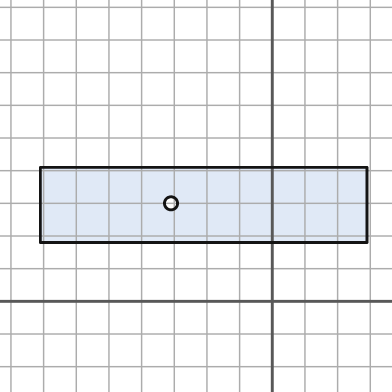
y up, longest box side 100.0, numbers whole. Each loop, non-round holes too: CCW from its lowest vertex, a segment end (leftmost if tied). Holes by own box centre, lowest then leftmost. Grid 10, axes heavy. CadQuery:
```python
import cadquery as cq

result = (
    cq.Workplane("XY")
    .moveTo(-71.0, 18.0)
    .lineTo(29.0, 18.0)
    .lineTo(29.0, 41.0)
    .lineTo(-71.0, 41.0)
    .close()
    .moveTo(-31.0, 30.0)
    .circle(2.0)
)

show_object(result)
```